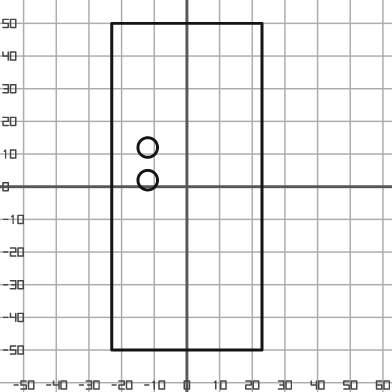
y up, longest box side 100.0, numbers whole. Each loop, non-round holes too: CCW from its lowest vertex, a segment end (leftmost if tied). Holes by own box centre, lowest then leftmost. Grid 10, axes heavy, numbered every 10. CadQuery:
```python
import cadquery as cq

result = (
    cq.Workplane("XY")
    .moveTo(-23.0, -50.0)
    .lineTo(23.0, -50.0)
    .lineTo(23.0, 50.0)
    .lineTo(-23.0, 50.0)
    .close()
    .moveTo(-12.0, 2.0)
    .circle(3.0)
    .moveTo(-12.0, 12.0)
    .circle(3.0)
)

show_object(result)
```